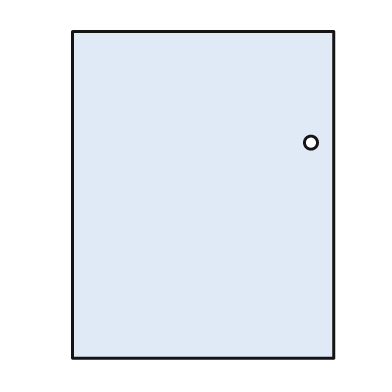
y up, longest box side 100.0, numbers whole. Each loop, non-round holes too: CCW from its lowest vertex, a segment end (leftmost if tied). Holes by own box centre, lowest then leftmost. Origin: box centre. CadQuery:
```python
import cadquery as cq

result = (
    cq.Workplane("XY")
    .moveTo(-40.0, -50.0)
    .lineTo(40.0, -50.0)
    .lineTo(40.0, 50.0)
    .lineTo(-40.0, 50.0)
    .close()
    .moveTo(33.0, 16.0)
    .circle(2.0)
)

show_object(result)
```